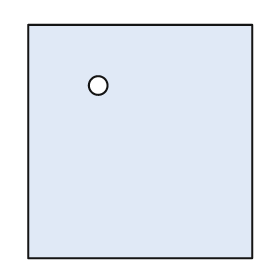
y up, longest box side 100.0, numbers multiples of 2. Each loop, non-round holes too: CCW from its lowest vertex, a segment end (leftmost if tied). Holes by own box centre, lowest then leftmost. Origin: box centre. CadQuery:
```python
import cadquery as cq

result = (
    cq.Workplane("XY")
    .moveTo(-48.0, -50.0)
    .lineTo(48.0, -50.0)
    .lineTo(48.0, 50.0)
    .lineTo(-48.0, 50.0)
    .close()
    .moveTo(-18.0, 24.0)
    .circle(4.0)
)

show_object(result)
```